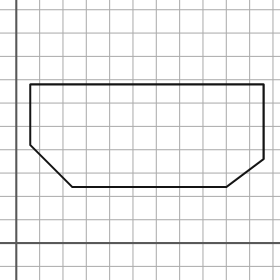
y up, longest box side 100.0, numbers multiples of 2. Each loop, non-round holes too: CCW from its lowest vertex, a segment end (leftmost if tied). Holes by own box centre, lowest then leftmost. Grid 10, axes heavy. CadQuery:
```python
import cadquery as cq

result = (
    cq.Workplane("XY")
    .moveTo(24.0, 24.0)
    .lineTo(90.0, 24.0)
    .lineTo(106.0, 36.0)
    .lineTo(106.0, 68.0)
    .lineTo(6.0, 68.0)
    .lineTo(6.0, 42.0)
    .close()
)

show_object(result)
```